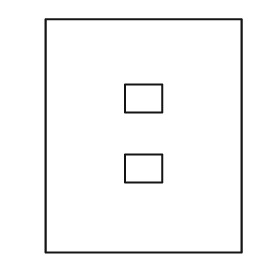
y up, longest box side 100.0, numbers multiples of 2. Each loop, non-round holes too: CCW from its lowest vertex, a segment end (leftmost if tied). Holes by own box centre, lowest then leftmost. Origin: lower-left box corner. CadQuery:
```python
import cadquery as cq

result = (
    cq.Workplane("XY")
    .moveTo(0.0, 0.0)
    .lineTo(84.0, 0.0)
    .lineTo(84.0, 100.0)
    .lineTo(0.0, 100.0)
    .close()
    .moveTo(34.0, 30.0)
    .lineTo(50.0, 30.0)
    .lineTo(50.0, 42.0)
    .lineTo(34.0, 42.0)
    .close()
    .moveTo(34.0, 60.0)
    .lineTo(50.0, 60.0)
    .lineTo(50.0, 72.0)
    .lineTo(34.0, 72.0)
    .close()
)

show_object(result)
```